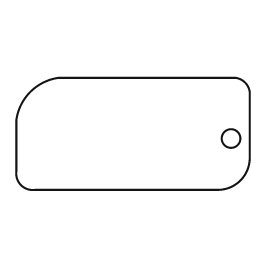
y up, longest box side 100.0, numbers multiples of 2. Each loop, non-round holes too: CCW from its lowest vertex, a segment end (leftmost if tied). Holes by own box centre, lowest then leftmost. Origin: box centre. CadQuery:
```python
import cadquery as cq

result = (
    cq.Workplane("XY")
    .moveTo(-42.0, -24.0)
    .lineTo(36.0, -24.0)
    .threePointArc((46.0, -20.0), (50.0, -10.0))
    .lineTo(50.0, 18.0)
    .threePointArc((48.0, 22.0), (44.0, 24.0))
    .lineTo(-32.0, 24.0)
    .threePointArc((-44.0, 18.0), (-50.0, 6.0))
    .lineTo(-50.0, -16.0)
    .threePointArc((-48.0, -22.0), (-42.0, -24.0))
    .close()
    .moveTo(42.0, -2.0)
    .circle(4.0)
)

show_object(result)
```